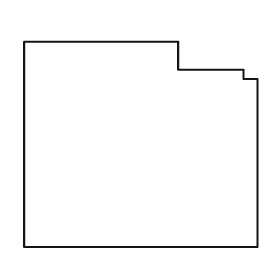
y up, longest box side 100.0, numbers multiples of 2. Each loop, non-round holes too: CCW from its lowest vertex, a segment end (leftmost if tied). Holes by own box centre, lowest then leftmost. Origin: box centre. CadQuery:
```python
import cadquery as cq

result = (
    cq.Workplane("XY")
    .moveTo(-50.0, -44.0)
    .lineTo(50.0, -44.0)
    .lineTo(50.0, 28.0)
    .lineTo(44.0, 28.0)
    .lineTo(44.0, 32.0)
    .lineTo(16.0, 32.0)
    .lineTo(16.0, 44.0)
    .lineTo(-50.0, 44.0)
    .close()
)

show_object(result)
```